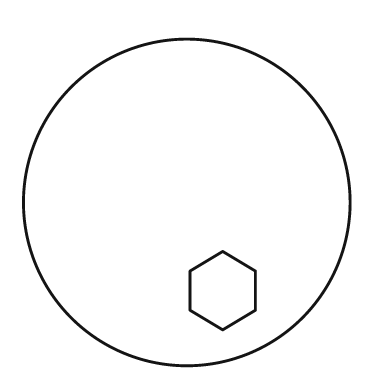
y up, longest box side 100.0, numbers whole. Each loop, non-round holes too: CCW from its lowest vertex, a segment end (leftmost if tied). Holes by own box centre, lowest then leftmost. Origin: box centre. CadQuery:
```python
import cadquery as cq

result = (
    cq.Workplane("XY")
    .moveTo(0.0, 0.0)
    .circle(50.0)
    .moveTo(11.0, -39.0)
    .lineTo(21.0, -33.0)
    .lineTo(21.0, -21.0)
    .lineTo(11.0, -15.0)
    .lineTo(1.0, -21.0)
    .lineTo(1.0, -33.0)
    .close()
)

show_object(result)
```